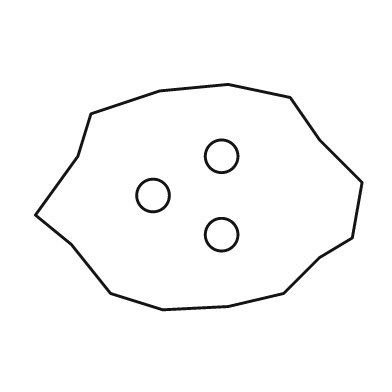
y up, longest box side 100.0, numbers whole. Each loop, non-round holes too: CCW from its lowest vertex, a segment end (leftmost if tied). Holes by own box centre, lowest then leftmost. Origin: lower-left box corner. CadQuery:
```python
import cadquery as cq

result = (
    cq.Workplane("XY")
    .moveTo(39.0, 0.0)
    .lineTo(59.0, 1.0)
    .lineTo(76.0, 5.0)
    .lineTo(87.0, 16.0)
    .lineTo(97.0, 22.0)
    .lineTo(100.0, 39.0)
    .lineTo(87.0, 52.0)
    .lineTo(78.0, 65.0)
    .lineTo(59.0, 69.0)
    .lineTo(38.0, 67.0)
    .lineTo(17.0, 60.0)
    .lineTo(13.0, 47.0)
    .lineTo(0.0, 29.0)
    .lineTo(11.0, 20.0)
    .lineTo(23.0, 5.0)
    .close()
    .moveTo(57.0, 23.0)
    .circle(5.0)
    .moveTo(36.0, 35.0)
    .circle(5.0)
    .moveTo(57.0, 47.0)
    .circle(5.0)
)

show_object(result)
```